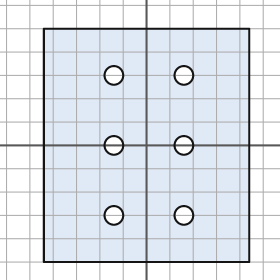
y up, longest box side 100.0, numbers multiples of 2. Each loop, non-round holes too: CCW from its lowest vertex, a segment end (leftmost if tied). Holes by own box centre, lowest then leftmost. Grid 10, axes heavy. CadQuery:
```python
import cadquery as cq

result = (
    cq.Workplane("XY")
    .moveTo(-44.0, -50.0)
    .lineTo(44.0, -50.0)
    .lineTo(44.0, 50.0)
    .lineTo(-44.0, 50.0)
    .close()
    .moveTo(-14.0, -30.0)
    .circle(4.0)
    .moveTo(16.0, -30.0)
    .circle(4.0)
    .moveTo(-14.0, 0.0)
    .circle(4.0)
    .moveTo(16.0, 0.0)
    .circle(4.0)
    .moveTo(-14.0, 30.0)
    .circle(4.0)
    .moveTo(16.0, 30.0)
    .circle(4.0)
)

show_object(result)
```